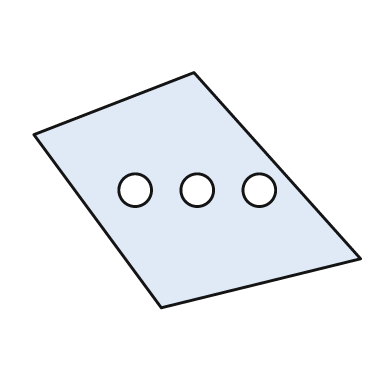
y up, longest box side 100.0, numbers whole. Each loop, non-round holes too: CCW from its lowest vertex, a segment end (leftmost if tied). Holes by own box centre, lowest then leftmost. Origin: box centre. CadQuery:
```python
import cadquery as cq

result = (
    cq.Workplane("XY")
    .moveTo(-11.0, -36.0)
    .lineTo(50.0, -21.0)
    .lineTo(-1.0, 36.0)
    .lineTo(-50.0, 17.0)
    .close()
    .moveTo(-19.0, 0.0)
    .circle(5.0)
    .moveTo(0.0, 0.0)
    .circle(5.0)
    .moveTo(19.0, 0.0)
    .circle(5.0)
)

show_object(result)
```